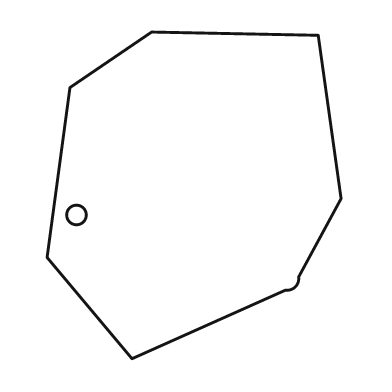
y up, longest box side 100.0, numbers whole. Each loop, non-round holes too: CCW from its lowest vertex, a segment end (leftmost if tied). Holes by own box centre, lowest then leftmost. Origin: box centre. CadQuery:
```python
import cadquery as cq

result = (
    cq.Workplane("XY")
    .moveTo(-19.0, -50.0)
    .lineTo(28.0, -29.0)
    .threePointArc((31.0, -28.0), (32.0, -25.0))
    .lineTo(45.0, -1.0)
    .lineTo(38.0, 49.0)
    .lineTo(-13.0, 50.0)
    .lineTo(-38.0, 33.0)
    .lineTo(-45.0, -19.0)
    .close()
    .moveTo(-36.0, -6.0)
    .circle(3.0)
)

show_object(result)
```